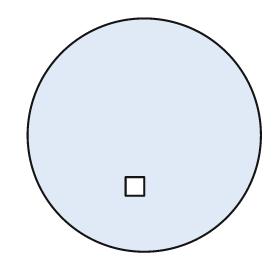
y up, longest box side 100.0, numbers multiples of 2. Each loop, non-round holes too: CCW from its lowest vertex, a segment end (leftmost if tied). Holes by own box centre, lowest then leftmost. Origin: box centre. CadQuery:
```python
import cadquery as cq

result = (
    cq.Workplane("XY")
    .moveTo(0.0, 0.0)
    .circle(50.0)
    .moveTo(-8.0, -26.0)
    .lineTo(0.0, -26.0)
    .lineTo(0.0, -18.0)
    .lineTo(-8.0, -18.0)
    .close()
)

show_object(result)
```